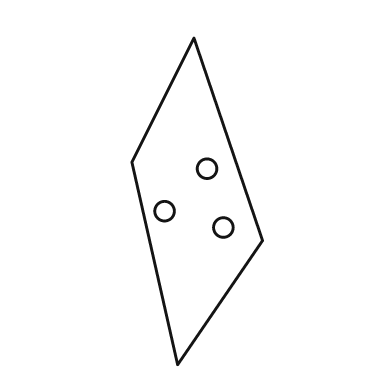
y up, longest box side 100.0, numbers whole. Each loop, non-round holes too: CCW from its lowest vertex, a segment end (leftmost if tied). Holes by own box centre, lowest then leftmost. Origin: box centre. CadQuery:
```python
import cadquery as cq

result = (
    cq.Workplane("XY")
    .moveTo(-6.0, -50.0)
    .lineTo(20.0, -12.0)
    .lineTo(-1.0, 50.0)
    .lineTo(-20.0, 12.0)
    .close()
    .moveTo(8.0, -8.0)
    .circle(3.0)
    .moveTo(-10.0, -3.0)
    .circle(3.0)
    .moveTo(3.0, 10.0)
    .circle(3.0)
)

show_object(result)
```